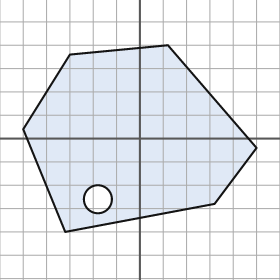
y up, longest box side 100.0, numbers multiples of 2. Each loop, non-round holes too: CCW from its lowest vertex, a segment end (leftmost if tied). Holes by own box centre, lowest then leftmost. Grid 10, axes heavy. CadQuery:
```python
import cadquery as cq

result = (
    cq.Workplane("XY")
    .moveTo(-32.0, -40.0)
    .lineTo(32.0, -28.0)
    .lineTo(50.0, -4.0)
    .lineTo(12.0, 40.0)
    .lineTo(-30.0, 36.0)
    .lineTo(-50.0, 4.0)
    .close()
    .moveTo(-18.0, -26.0)
    .circle(6.0)
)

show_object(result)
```